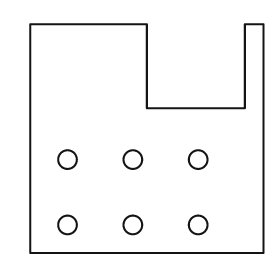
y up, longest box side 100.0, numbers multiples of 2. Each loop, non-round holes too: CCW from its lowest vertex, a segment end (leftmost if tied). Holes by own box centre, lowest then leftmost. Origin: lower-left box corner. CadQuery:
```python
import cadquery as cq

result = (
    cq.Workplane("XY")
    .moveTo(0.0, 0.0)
    .lineTo(100.0, 0.0)
    .lineTo(100.0, 98.0)
    .lineTo(92.0, 98.0)
    .lineTo(92.0, 62.0)
    .lineTo(50.0, 62.0)
    .lineTo(50.0, 98.0)
    .lineTo(0.0, 98.0)
    .close()
    .moveTo(16.0, 12.0)
    .circle(4.0)
    .moveTo(44.0, 12.0)
    .circle(4.0)
    .moveTo(72.0, 12.0)
    .circle(4.0)
    .moveTo(16.0, 40.0)
    .circle(4.0)
    .moveTo(44.0, 40.0)
    .circle(4.0)
    .moveTo(72.0, 40.0)
    .circle(4.0)
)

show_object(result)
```